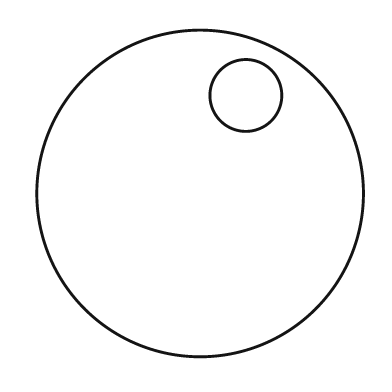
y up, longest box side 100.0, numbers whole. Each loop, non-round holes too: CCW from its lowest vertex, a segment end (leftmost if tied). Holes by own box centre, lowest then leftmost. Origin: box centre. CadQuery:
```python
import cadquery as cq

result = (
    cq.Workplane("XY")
    .moveTo(0.0, 0.0)
    .circle(50.0)
    .moveTo(14.0, 30.0)
    .circle(11.0)
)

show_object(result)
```